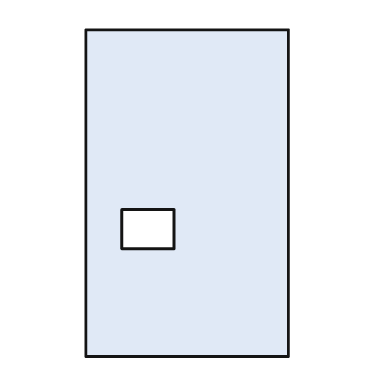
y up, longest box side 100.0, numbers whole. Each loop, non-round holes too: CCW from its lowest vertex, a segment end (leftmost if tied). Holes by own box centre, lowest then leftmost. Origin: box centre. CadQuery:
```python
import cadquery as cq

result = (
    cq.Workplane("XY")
    .moveTo(-31.0, -50.0)
    .lineTo(31.0, -50.0)
    .lineTo(31.0, 50.0)
    .lineTo(-31.0, 50.0)
    .close()
    .moveTo(-20.0, -17.0)
    .lineTo(-4.0, -17.0)
    .lineTo(-4.0, -5.0)
    .lineTo(-20.0, -5.0)
    .close()
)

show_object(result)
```